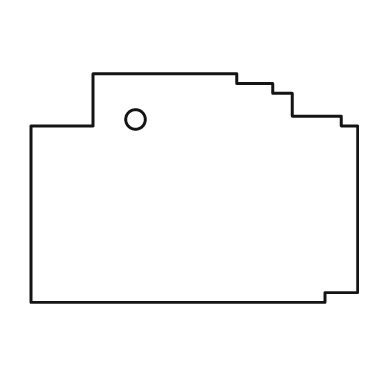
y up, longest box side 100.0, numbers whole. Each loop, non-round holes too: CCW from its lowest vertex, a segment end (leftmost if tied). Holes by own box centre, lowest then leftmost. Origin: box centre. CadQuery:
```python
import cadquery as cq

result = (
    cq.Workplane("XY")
    .moveTo(-50.0, -35.0)
    .lineTo(40.0, -35.0)
    .lineTo(40.0, -32.0)
    .lineTo(50.0, -32.0)
    .lineTo(50.0, 19.0)
    .lineTo(45.0, 19.0)
    .lineTo(45.0, 22.0)
    .lineTo(30.0, 22.0)
    .lineTo(30.0, 29.0)
    .lineTo(24.0, 29.0)
    .lineTo(24.0, 32.0)
    .lineTo(13.0, 32.0)
    .lineTo(13.0, 35.0)
    .lineTo(-31.0, 35.0)
    .lineTo(-31.0, 19.0)
    .lineTo(-50.0, 19.0)
    .close()
    .moveTo(-18.0, 21.0)
    .circle(3.0)
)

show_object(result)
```